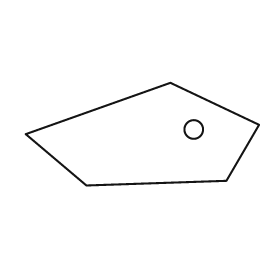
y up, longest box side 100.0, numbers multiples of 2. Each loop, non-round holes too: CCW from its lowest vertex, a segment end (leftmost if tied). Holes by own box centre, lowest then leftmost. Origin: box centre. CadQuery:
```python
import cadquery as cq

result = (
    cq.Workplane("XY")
    .moveTo(-24.0, -22.0)
    .lineTo(36.0, -20.0)
    .lineTo(50.0, 4.0)
    .lineTo(12.0, 22.0)
    .lineTo(-50.0, 0.0)
    .close()
    .moveTo(22.0, 2.0)
    .circle(4.0)
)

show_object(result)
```